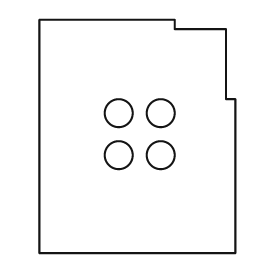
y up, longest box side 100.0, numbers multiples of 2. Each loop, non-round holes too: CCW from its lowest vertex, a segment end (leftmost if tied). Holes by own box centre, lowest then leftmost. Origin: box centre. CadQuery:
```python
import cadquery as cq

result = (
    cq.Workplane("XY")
    .moveTo(-42.0, -50.0)
    .lineTo(42.0, -50.0)
    .lineTo(42.0, 16.0)
    .lineTo(38.0, 16.0)
    .lineTo(38.0, 46.0)
    .lineTo(16.0, 46.0)
    .lineTo(16.0, 50.0)
    .lineTo(-42.0, 50.0)
    .close()
    .moveTo(-8.0, -8.0)
    .circle(6.0)
    .moveTo(10.0, -8.0)
    .circle(6.0)
    .moveTo(-8.0, 10.0)
    .circle(6.0)
    .moveTo(10.0, 10.0)
    .circle(6.0)
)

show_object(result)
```